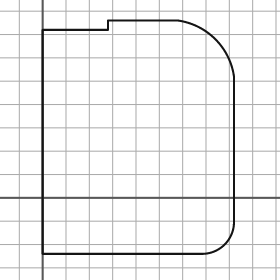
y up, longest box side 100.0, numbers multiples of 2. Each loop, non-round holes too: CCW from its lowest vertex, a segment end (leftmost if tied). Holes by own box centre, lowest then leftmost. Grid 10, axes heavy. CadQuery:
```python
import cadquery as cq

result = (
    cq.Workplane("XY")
    .moveTo(0.0, -24.0)
    .lineTo(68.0, -24.0)
    .threePointArc((78.0, -20.0), (82.0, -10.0))
    .lineTo(82.0, 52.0)
    .threePointArc((74.0, 68.0), (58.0, 76.0))
    .lineTo(28.0, 76.0)
    .lineTo(28.0, 72.0)
    .lineTo(0.0, 72.0)
    .close()
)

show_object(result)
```